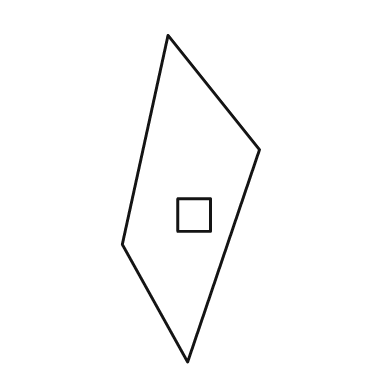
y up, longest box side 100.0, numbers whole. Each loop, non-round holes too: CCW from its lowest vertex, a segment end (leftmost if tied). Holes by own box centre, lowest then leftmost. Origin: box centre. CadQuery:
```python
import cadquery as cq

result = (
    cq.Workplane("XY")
    .moveTo(-1.0, -50.0)
    .lineTo(21.0, 15.0)
    .lineTo(-7.0, 50.0)
    .lineTo(-21.0, -14.0)
    .close()
    .moveTo(-4.0, -10.0)
    .lineTo(6.0, -10.0)
    .lineTo(6.0, 0.0)
    .lineTo(-4.0, 0.0)
    .close()
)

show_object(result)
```